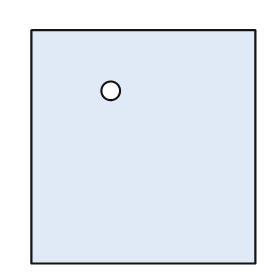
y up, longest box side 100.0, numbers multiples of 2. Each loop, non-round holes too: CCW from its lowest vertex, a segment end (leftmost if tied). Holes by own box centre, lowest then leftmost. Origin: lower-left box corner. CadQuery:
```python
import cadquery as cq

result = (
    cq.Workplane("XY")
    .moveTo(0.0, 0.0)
    .lineTo(96.0, 0.0)
    .lineTo(96.0, 100.0)
    .lineTo(0.0, 100.0)
    .close()
    .moveTo(34.0, 74.0)
    .circle(4.0)
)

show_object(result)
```